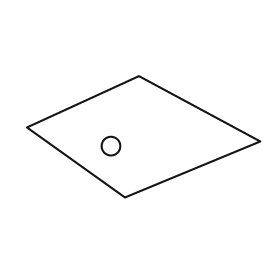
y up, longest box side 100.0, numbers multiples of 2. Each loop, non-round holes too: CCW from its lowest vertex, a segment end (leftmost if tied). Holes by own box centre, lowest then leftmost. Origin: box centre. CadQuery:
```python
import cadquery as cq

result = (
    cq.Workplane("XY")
    .moveTo(-8.0, -26.0)
    .lineTo(50.0, -2.0)
    .lineTo(-2.0, 26.0)
    .lineTo(-50.0, 4.0)
    .close()
    .moveTo(-14.0, -4.0)
    .circle(4.0)
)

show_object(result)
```